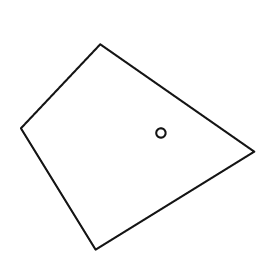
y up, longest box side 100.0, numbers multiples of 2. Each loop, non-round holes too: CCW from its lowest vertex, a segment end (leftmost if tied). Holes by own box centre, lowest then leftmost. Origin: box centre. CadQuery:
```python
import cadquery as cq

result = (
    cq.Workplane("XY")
    .moveTo(-18.0, -44.0)
    .lineTo(50.0, -2.0)
    .lineTo(-16.0, 44.0)
    .lineTo(-50.0, 8.0)
    .close()
    .moveTo(10.0, 6.0)
    .circle(2.0)
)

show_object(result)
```